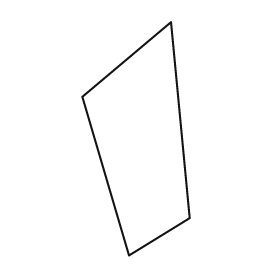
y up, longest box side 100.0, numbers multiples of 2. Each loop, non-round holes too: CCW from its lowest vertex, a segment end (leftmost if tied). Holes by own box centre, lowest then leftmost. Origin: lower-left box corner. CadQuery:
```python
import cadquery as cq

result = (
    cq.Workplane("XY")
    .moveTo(20.0, 0.0)
    .lineTo(46.0, 16.0)
    .lineTo(38.0, 100.0)
    .lineTo(0.0, 68.0)
    .close()
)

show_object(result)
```